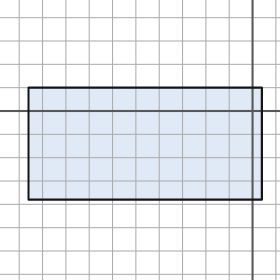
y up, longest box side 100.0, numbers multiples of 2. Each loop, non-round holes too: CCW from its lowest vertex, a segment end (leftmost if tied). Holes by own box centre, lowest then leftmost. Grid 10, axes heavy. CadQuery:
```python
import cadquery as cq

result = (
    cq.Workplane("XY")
    .moveTo(-96.0, -38.0)
    .lineTo(4.0, -38.0)
    .lineTo(4.0, 10.0)
    .lineTo(-96.0, 10.0)
    .close()
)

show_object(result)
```